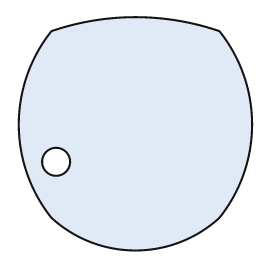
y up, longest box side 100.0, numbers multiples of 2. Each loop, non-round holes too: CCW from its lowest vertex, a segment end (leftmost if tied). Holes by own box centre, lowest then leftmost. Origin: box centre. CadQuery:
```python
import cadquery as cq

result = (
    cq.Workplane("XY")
    .moveTo(-36.0, -36.0)
    .threePointArc((0.0, -50.0), (36.0, -36.0))
    .threePointArc((50.0, 4.0), (36.0, 44.0))
    .threePointArc((0.0, 50.0), (-36.0, 44.0))
    .threePointArc((-50.0, 4.0), (-36.0, -36.0))
    .close()
    .moveTo(-34.0, -12.0)
    .circle(6.0)
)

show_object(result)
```